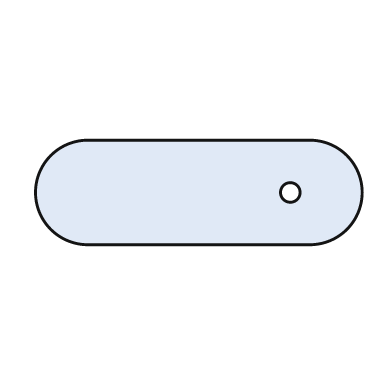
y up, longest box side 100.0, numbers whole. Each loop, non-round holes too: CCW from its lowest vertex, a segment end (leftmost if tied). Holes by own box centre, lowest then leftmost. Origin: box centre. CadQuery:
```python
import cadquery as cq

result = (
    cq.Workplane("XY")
    .moveTo(-34.0, -16.0)
    .lineTo(34.0, -16.0)
    .threePointArc((50.0, 0.0), (34.0, 16.0))
    .lineTo(-34.0, 16.0)
    .threePointArc((-50.0, 0.0), (-34.0, -16.0))
    .close()
    .moveTo(28.0, 0.0)
    .circle(3.0)
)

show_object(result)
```